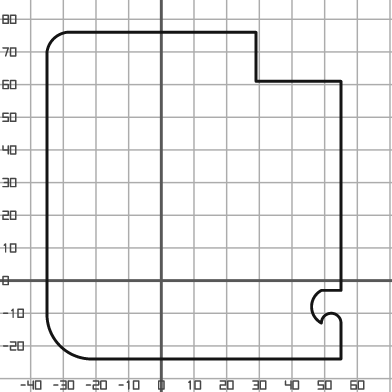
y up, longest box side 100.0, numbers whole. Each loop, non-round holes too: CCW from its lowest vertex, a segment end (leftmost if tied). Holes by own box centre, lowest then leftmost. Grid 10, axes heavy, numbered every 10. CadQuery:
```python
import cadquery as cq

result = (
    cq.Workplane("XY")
    .moveTo(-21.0, -24.0)
    .lineTo(55.0, -24.0)
    .lineTo(55.0, -13.0)
    .threePointArc((52.0, -10.0), (49.0, -13.0))
    .threePointArc((46.0, -8.0), (49.0, -3.0))
    .lineTo(55.0, -3.0)
    .lineTo(55.0, 61.0)
    .lineTo(29.0, 61.0)
    .lineTo(29.0, 76.0)
    .lineTo(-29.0, 76.0)
    .threePointArc((-33.0, 74.0), (-35.0, 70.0))
    .lineTo(-35.0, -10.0)
    .threePointArc((-31.0, -20.0), (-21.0, -24.0))
    .close()
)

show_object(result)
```